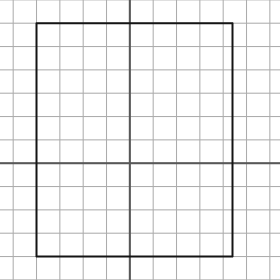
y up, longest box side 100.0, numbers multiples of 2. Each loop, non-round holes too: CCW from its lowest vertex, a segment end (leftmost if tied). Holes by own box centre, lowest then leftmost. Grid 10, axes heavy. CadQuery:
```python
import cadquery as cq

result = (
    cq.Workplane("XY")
    .moveTo(-40.0, -40.0)
    .lineTo(44.0, -40.0)
    .lineTo(44.0, 60.0)
    .lineTo(-40.0, 60.0)
    .close()
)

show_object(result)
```